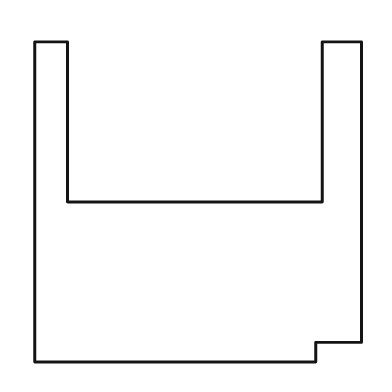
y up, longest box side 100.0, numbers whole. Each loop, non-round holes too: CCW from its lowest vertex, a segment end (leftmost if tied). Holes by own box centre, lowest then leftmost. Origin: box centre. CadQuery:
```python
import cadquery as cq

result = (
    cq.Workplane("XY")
    .moveTo(-50.0, -49.0)
    .lineTo(36.0, -49.0)
    .lineTo(36.0, -43.0)
    .lineTo(50.0, -43.0)
    .lineTo(50.0, 49.0)
    .lineTo(38.0, 49.0)
    .lineTo(38.0, 0.0)
    .lineTo(-40.0, 0.0)
    .lineTo(-40.0, 49.0)
    .lineTo(-50.0, 49.0)
    .close()
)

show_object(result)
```